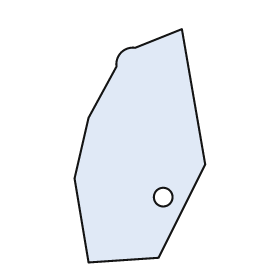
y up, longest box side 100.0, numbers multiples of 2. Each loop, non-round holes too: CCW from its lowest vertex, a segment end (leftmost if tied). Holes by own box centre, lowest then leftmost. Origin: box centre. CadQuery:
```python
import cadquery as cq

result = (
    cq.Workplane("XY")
    .moveTo(-22.0, -50.0)
    .lineTo(8.0, -48.0)
    .lineTo(28.0, -8.0)
    .lineTo(18.0, 50.0)
    .lineTo(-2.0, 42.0)
    .threePointArc((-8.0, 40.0), (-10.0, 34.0))
    .lineTo(-22.0, 12.0)
    .lineTo(-28.0, -14.0)
    .close()
    .moveTo(10.0, -22.0)
    .circle(4.0)
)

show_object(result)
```